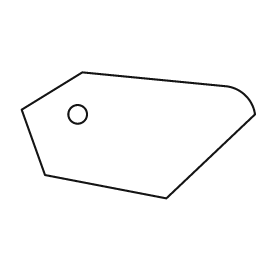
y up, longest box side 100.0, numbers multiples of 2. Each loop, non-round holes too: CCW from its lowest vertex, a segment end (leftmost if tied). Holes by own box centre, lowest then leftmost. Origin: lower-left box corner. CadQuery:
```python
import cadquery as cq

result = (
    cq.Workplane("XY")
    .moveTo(62.0, 0.0)
    .lineTo(100.0, 36.0)
    .threePointArc((96.0, 44.0), (88.0, 48.0))
    .lineTo(26.0, 54.0)
    .lineTo(0.0, 38.0)
    .lineTo(10.0, 10.0)
    .close()
    .moveTo(24.0, 36.0)
    .circle(4.0)
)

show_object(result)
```